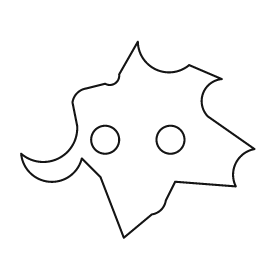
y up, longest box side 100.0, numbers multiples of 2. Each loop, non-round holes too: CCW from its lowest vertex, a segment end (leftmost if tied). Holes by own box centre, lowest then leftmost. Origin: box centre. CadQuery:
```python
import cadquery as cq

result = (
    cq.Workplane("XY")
    .moveTo(-6.0, -42.0)
    .lineTo(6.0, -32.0)
    .threePointArc((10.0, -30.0), (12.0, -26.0))
    .lineTo(16.0, -18.0)
    .lineTo(42.0, -20.0)
    .threePointArc((42.0, -10.0), (50.0, -4.0))
    .lineTo(30.0, 10.0)
    .threePointArc((28.0, 20.0), (36.0, 26.0))
    .lineTo(22.0, 32.0)
    .threePointArc((8.0, 30.0), (0.0, 42.0))
    .lineTo(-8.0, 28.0)
    .threePointArc((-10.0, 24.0), (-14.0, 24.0))
    .lineTo(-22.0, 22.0)
    .threePointArc((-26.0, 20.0), (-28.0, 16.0))
    .lineTo(-26.0, 6.0)
    .threePointArc((-34.0, -8.0), (-50.0, -6.0))
    .threePointArc((-38.0, -18.0), (-24.0, -8.0))
    .lineTo(-16.0, -16.0)
    .close()
    .moveTo(-14.0, 0.0)
    .circle(6.0)
    .moveTo(14.0, 0.0)
    .circle(6.0)
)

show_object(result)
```